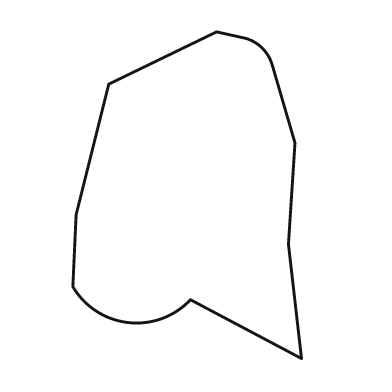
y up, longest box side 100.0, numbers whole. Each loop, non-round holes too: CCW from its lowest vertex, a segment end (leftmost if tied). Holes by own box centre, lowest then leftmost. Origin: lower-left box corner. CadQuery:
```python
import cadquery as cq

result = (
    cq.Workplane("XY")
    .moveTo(70.0, 0.0)
    .lineTo(66.0, 35.0)
    .lineTo(68.0, 66.0)
    .lineTo(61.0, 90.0)
    .threePointArc((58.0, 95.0), (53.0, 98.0))
    .lineTo(44.0, 100.0)
    .lineTo(11.0, 84.0)
    .lineTo(1.0, 44.0)
    .lineTo(0.0, 22.0)
    .threePointArc((17.0, 11.0), (36.0, 18.0))
    .close()
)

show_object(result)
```